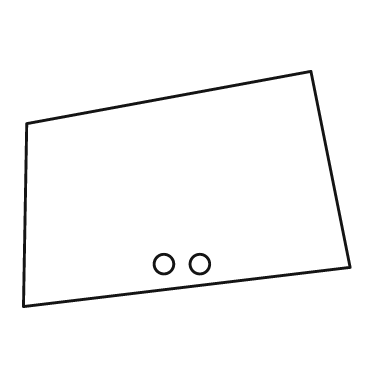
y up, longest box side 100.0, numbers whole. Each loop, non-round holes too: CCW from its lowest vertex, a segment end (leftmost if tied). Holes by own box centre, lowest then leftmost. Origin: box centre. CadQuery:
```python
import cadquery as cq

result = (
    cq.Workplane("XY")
    .moveTo(-50.0, -36.0)
    .lineTo(50.0, -24.0)
    .lineTo(38.0, 36.0)
    .lineTo(-49.0, 20.0)
    .close()
    .moveTo(-7.0, -23.0)
    .circle(3.0)
    .moveTo(4.0, -23.0)
    .circle(3.0)
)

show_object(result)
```